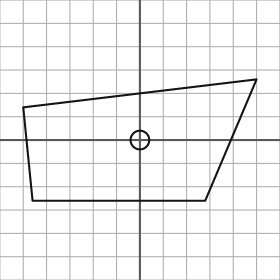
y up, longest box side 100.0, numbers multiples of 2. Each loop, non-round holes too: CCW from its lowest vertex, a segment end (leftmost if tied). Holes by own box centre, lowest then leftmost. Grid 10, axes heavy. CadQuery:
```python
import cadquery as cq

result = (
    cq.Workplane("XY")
    .moveTo(-46.0, -26.0)
    .lineTo(28.0, -26.0)
    .lineTo(50.0, 26.0)
    .lineTo(-50.0, 14.0)
    .close()
    .moveTo(0.0, 0.0)
    .circle(4.0)
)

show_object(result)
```